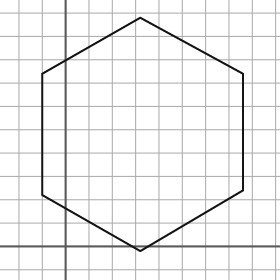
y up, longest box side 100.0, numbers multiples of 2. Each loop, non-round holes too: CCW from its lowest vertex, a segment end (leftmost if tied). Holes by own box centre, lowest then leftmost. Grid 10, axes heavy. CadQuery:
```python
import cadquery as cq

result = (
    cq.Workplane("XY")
    .moveTo(32.0, -2.0)
    .lineTo(76.0, 24.0)
    .lineTo(76.0, 74.0)
    .lineTo(32.0, 98.0)
    .lineTo(-10.0, 74.0)
    .lineTo(-10.0, 22.0)
    .close()
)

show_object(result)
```